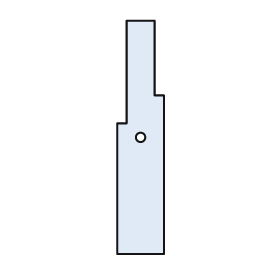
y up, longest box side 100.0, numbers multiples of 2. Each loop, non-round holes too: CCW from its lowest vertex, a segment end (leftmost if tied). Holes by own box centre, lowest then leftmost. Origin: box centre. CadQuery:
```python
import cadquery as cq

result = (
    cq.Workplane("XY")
    .moveTo(-10.0, -50.0)
    .lineTo(10.0, -50.0)
    .lineTo(10.0, 18.0)
    .lineTo(6.0, 18.0)
    .lineTo(6.0, 50.0)
    .lineTo(-6.0, 50.0)
    .lineTo(-6.0, 6.0)
    .lineTo(-10.0, 6.0)
    .close()
    .moveTo(0.0, 0.0)
    .circle(2.0)
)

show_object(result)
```